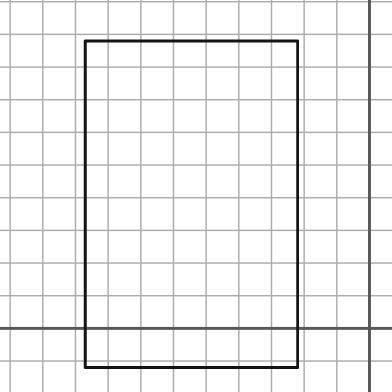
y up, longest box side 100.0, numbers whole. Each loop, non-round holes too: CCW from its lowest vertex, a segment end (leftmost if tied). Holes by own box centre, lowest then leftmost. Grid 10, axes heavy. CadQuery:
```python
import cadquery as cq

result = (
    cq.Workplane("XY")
    .moveTo(-87.0, -12.0)
    .lineTo(-22.0, -12.0)
    .lineTo(-22.0, 88.0)
    .lineTo(-87.0, 88.0)
    .close()
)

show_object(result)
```